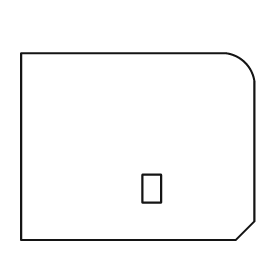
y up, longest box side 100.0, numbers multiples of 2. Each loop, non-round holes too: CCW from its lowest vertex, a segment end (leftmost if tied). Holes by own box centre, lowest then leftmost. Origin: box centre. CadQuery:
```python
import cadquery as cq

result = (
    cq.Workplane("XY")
    .moveTo(-50.0, -40.0)
    .lineTo(42.0, -40.0)
    .lineTo(50.0, -32.0)
    .lineTo(50.0, 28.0)
    .threePointArc((46.0, 36.0), (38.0, 40.0))
    .lineTo(-50.0, 40.0)
    .close()
    .moveTo(2.0, -24.0)
    .lineTo(10.0, -24.0)
    .lineTo(10.0, -12.0)
    .lineTo(2.0, -12.0)
    .close()
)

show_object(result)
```